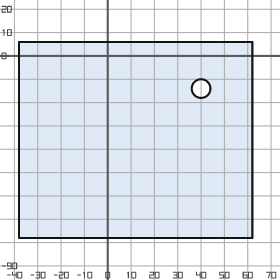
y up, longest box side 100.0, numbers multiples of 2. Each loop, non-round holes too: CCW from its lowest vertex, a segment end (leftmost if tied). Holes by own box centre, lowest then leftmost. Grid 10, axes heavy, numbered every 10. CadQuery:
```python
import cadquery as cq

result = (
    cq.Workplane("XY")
    .moveTo(-38.0, -78.0)
    .lineTo(62.0, -78.0)
    .lineTo(62.0, 6.0)
    .lineTo(-38.0, 6.0)
    .close()
    .moveTo(40.0, -14.0)
    .circle(4.0)
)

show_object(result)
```